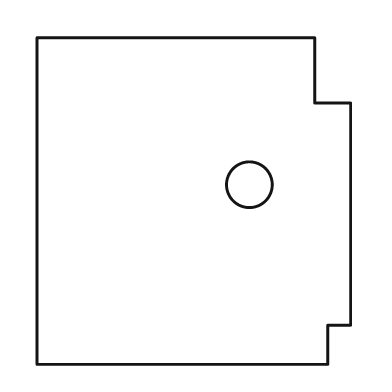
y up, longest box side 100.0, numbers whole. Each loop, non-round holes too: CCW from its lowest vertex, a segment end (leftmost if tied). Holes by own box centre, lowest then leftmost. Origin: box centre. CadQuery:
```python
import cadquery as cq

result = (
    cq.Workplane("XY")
    .moveTo(-48.0, -50.0)
    .lineTo(41.0, -50.0)
    .lineTo(41.0, -38.0)
    .lineTo(48.0, -38.0)
    .lineTo(48.0, 30.0)
    .lineTo(37.0, 30.0)
    .lineTo(37.0, 50.0)
    .lineTo(-48.0, 50.0)
    .close()
    .moveTo(17.0, 5.0)
    .circle(7.0)
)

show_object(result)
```